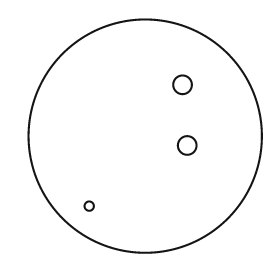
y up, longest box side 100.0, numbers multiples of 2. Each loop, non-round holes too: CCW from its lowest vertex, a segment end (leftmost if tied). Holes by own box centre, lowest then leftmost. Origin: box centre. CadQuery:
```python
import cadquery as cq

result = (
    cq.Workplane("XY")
    .moveTo(0.0, 0.0)
    .circle(50.0)
    .moveTo(-24.0, -30.0)
    .circle(2.0)
    .moveTo(18.0, -4.0)
    .circle(4.0)
    .moveTo(16.0, 22.0)
    .circle(4.0)
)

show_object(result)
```